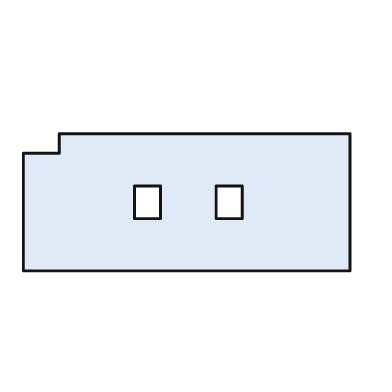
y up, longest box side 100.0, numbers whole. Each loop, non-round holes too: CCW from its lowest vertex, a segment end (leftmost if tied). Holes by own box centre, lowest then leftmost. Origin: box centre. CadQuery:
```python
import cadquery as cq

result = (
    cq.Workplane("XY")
    .moveTo(-50.0, -21.0)
    .lineTo(50.0, -21.0)
    .lineTo(50.0, 21.0)
    .lineTo(-39.0, 21.0)
    .lineTo(-39.0, 15.0)
    .lineTo(-50.0, 15.0)
    .close()
    .moveTo(-16.0, -5.0)
    .lineTo(-8.0, -5.0)
    .lineTo(-8.0, 5.0)
    .lineTo(-16.0, 5.0)
    .close()
    .moveTo(9.0, -5.0)
    .lineTo(17.0, -5.0)
    .lineTo(17.0, 5.0)
    .lineTo(9.0, 5.0)
    .close()
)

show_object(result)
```